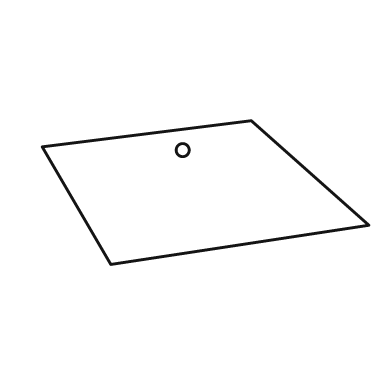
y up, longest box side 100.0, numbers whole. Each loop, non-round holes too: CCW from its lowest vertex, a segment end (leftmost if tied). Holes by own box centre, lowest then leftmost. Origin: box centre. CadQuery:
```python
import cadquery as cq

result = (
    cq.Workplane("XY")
    .moveTo(-29.0, -22.0)
    .lineTo(50.0, -10.0)
    .lineTo(14.0, 22.0)
    .lineTo(-50.0, 14.0)
    .close()
    .moveTo(-7.0, 13.0)
    .circle(2.0)
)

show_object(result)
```